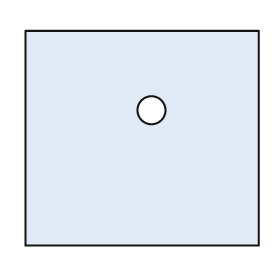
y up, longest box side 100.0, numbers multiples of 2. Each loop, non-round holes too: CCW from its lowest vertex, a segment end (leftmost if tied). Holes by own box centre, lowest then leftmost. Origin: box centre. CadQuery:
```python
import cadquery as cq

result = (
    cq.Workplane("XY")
    .moveTo(-50.0, -46.0)
    .lineTo(50.0, -46.0)
    .lineTo(50.0, 46.0)
    .lineTo(-50.0, 46.0)
    .close()
    .moveTo(4.0, 12.0)
    .circle(6.0)
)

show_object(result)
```